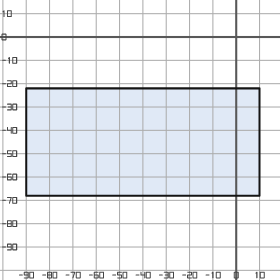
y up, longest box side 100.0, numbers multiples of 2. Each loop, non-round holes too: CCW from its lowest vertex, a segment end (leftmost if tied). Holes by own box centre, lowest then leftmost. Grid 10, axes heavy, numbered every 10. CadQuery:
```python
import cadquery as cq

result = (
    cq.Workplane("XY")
    .moveTo(-90.0, -68.0)
    .lineTo(10.0, -68.0)
    .lineTo(10.0, -22.0)
    .lineTo(-90.0, -22.0)
    .close()
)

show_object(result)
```